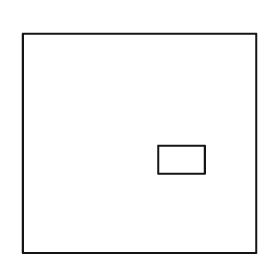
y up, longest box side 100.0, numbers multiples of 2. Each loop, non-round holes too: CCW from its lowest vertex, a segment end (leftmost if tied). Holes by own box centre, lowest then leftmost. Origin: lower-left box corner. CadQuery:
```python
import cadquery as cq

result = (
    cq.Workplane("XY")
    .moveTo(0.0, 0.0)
    .lineTo(100.0, 0.0)
    .lineTo(100.0, 94.0)
    .lineTo(0.0, 94.0)
    .close()
    .moveTo(58.0, 34.0)
    .lineTo(78.0, 34.0)
    .lineTo(78.0, 46.0)
    .lineTo(58.0, 46.0)
    .close()
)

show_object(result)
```